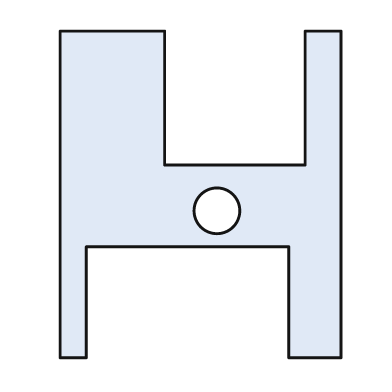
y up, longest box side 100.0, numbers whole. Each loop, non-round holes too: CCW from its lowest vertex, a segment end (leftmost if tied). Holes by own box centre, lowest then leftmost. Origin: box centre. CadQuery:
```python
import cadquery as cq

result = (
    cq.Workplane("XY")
    .moveTo(-43.0, -50.0)
    .lineTo(-35.0, -50.0)
    .lineTo(-35.0, -16.0)
    .lineTo(27.0, -16.0)
    .lineTo(27.0, -50.0)
    .lineTo(43.0, -50.0)
    .lineTo(43.0, 50.0)
    .lineTo(32.0, 50.0)
    .lineTo(32.0, 9.0)
    .lineTo(-11.0, 9.0)
    .lineTo(-11.0, 50.0)
    .lineTo(-43.0, 50.0)
    .close()
    .moveTo(5.0, -5.0)
    .circle(7.0)
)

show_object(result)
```